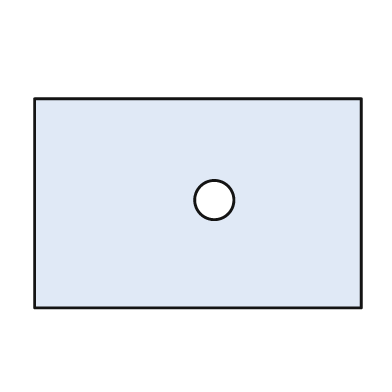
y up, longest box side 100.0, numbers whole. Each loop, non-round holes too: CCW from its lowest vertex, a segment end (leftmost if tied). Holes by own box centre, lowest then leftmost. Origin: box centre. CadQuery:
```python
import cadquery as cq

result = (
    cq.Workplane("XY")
    .moveTo(-50.0, -32.0)
    .lineTo(50.0, -32.0)
    .lineTo(50.0, 32.0)
    .lineTo(-50.0, 32.0)
    .close()
    .moveTo(5.0, 1.0)
    .circle(6.0)
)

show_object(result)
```